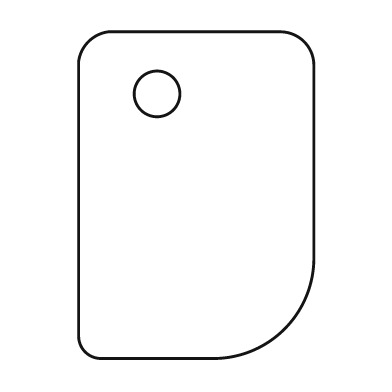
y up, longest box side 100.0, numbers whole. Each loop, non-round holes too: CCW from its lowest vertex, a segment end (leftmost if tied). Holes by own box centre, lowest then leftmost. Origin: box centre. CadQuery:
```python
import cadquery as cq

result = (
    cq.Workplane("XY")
    .moveTo(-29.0, -50.0)
    .lineTo(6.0, -50.0)
    .threePointArc((27.0, -41.0), (36.0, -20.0))
    .lineTo(36.0, 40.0)
    .threePointArc((33.0, 47.0), (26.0, 50.0))
    .lineTo(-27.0, 50.0)
    .threePointArc((-33.0, 47.0), (-36.0, 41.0))
    .lineTo(-36.0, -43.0)
    .threePointArc((-34.0, -48.0), (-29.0, -50.0))
    .close()
    .moveTo(-12.0, 31.0)
    .circle(7.0)
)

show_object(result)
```